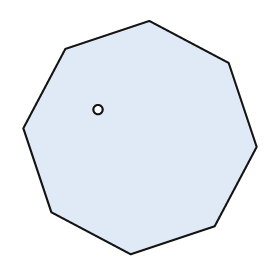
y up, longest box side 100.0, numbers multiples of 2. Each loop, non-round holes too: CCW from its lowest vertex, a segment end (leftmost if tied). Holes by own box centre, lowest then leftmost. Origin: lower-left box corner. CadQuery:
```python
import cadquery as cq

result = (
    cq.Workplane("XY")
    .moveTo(46.0, 0.0)
    .lineTo(82.0, 12.0)
    .lineTo(100.0, 46.0)
    .lineTo(88.0, 82.0)
    .lineTo(54.0, 100.0)
    .lineTo(18.0, 88.0)
    .lineTo(0.0, 54.0)
    .lineTo(12.0, 18.0)
    .close()
    .moveTo(32.0, 62.0)
    .circle(2.0)
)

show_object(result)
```